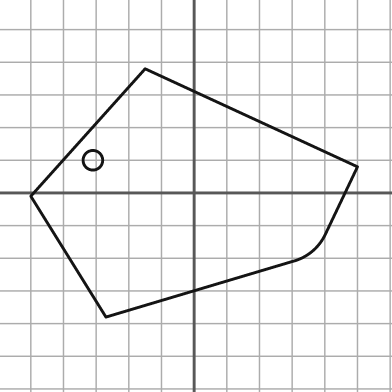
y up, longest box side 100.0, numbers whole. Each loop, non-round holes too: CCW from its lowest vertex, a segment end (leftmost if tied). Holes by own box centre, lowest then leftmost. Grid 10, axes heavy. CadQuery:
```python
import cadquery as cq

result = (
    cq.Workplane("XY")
    .moveTo(-27.0, -38.0)
    .lineTo(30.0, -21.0)
    .threePointArc((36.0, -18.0), (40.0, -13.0))
    .lineTo(50.0, 8.0)
    .lineTo(-15.0, 38.0)
    .lineTo(-50.0, -1.0)
    .close()
    .moveTo(-31.0, 10.0)
    .circle(3.0)
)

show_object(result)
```